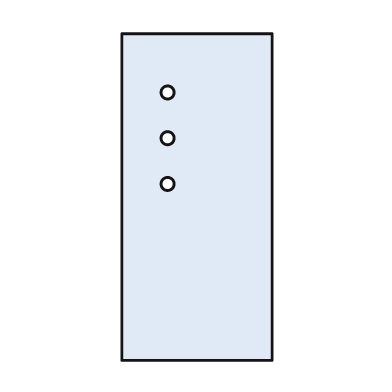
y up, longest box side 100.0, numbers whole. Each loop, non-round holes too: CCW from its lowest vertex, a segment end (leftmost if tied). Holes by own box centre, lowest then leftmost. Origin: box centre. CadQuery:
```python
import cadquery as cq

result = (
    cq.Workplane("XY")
    .moveTo(-23.0, -50.0)
    .lineTo(23.0, -50.0)
    .lineTo(23.0, 50.0)
    .lineTo(-23.0, 50.0)
    .close()
    .moveTo(-9.0, 4.0)
    .circle(2.0)
    .moveTo(-9.0, 18.0)
    .circle(2.0)
    .moveTo(-9.0, 32.0)
    .circle(2.0)
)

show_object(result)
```